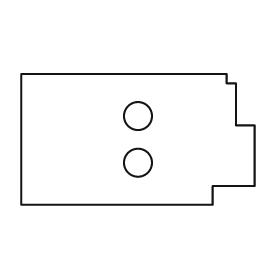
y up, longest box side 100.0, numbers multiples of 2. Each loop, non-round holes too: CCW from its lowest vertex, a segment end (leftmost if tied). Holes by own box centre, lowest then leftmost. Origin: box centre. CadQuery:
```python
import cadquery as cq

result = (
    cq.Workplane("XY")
    .moveTo(-50.0, -28.0)
    .lineTo(32.0, -28.0)
    .lineTo(32.0, -20.0)
    .lineTo(50.0, -20.0)
    .lineTo(50.0, 6.0)
    .lineTo(42.0, 6.0)
    .lineTo(42.0, 24.0)
    .lineTo(38.0, 24.0)
    .lineTo(38.0, 28.0)
    .lineTo(-50.0, 28.0)
    .close()
    .moveTo(0.0, -10.0)
    .circle(6.0)
    .moveTo(0.0, 10.0)
    .circle(6.0)
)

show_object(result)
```